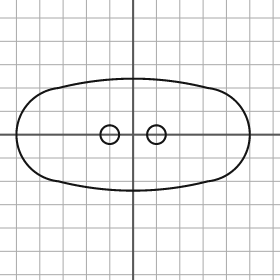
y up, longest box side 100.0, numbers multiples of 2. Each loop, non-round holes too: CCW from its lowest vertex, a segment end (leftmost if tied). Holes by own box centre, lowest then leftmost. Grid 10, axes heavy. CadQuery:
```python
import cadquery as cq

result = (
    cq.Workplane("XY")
    .moveTo(-32.0, -20.0)
    .threePointArc((0.0, -24.0), (32.0, -20.0))
    .threePointArc((50.0, 0.0), (32.0, 20.0))
    .threePointArc((0.0, 24.0), (-32.0, 20.0))
    .threePointArc((-50.0, 0.0), (-32.0, -20.0))
    .close()
    .moveTo(-10.0, 0.0)
    .circle(4.0)
    .moveTo(10.0, 0.0)
    .circle(4.0)
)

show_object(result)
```